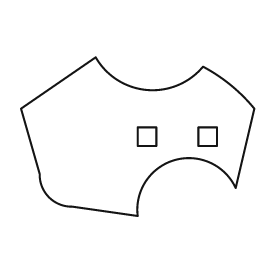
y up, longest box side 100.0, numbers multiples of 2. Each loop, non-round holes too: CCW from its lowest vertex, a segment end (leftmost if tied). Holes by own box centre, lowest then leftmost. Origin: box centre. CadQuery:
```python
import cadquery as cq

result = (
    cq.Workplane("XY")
    .moveTo(0.0, -34.0)
    .threePointArc((16.0, -10.0), (42.0, -22.0))
    .lineTo(50.0, 12.0)
    .threePointArc((40.0, 22.0), (28.0, 30.0))
    .threePointArc((4.0, 20.0), (-18.0, 34.0))
    .lineTo(-50.0, 12.0)
    .lineTo(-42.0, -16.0)
    .threePointArc((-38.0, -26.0), (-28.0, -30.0))
    .close()
    .moveTo(0.0, -4.0)
    .lineTo(8.0, -4.0)
    .lineTo(8.0, 4.0)
    .lineTo(0.0, 4.0)
    .close()
    .moveTo(26.0, -4.0)
    .lineTo(34.0, -4.0)
    .lineTo(34.0, 4.0)
    .lineTo(26.0, 4.0)
    .close()
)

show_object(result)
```